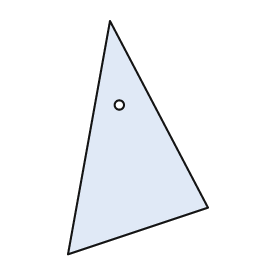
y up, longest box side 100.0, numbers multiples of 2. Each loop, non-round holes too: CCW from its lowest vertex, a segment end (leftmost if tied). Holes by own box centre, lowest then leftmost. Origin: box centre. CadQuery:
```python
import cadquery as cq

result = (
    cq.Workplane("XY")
    .moveTo(-30.0, -50.0)
    .lineTo(30.0, -30.0)
    .lineTo(-12.0, 50.0)
    .close()
    .moveTo(-8.0, 14.0)
    .circle(2.0)
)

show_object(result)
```